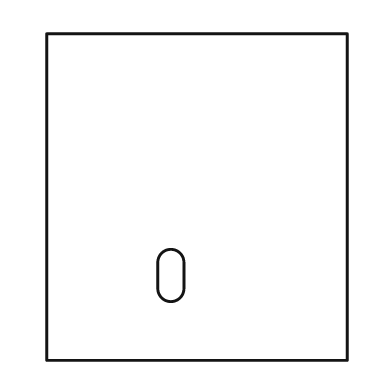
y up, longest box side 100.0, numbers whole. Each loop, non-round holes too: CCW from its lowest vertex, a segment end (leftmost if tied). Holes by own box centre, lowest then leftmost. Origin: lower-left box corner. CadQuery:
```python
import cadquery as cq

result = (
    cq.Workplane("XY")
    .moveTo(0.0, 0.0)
    .lineTo(92.0, 0.0)
    .lineTo(92.0, 100.0)
    .lineTo(0.0, 100.0)
    .close()
    .moveTo(34.0, 22.0)
    .threePointArc((38.0, 18.0), (42.0, 22.0))
    .lineTo(42.0, 30.0)
    .threePointArc((38.0, 34.0), (34.0, 30.0))
    .close()
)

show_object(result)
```